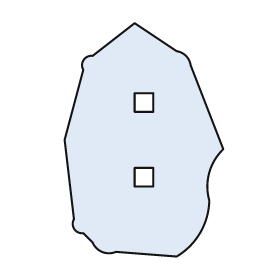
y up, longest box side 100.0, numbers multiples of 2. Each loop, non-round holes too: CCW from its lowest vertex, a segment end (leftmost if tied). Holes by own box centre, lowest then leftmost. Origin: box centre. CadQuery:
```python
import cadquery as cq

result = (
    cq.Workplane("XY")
    .moveTo(14.0, -50.0)
    .threePointArc((24.0, -40.0), (28.0, -26.0))
    .threePointArc((28.0, -14.0), (34.0, -4.0))
    .lineTo(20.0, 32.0)
    .threePointArc((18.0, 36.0), (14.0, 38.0))
    .lineTo(-4.0, 50.0)
    .lineTo(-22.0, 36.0)
    .threePointArc((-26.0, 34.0), (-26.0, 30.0))
    .lineTo(-34.0, 0.0)
    .lineTo(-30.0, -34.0)
    .threePointArc((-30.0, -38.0), (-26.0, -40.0))
    .lineTo(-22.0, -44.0)
    .threePointArc((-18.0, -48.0), (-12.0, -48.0))
    .close()
    .moveTo(-4.0, -20.0)
    .lineTo(4.0, -20.0)
    .lineTo(4.0, -12.0)
    .lineTo(-4.0, -12.0)
    .close()
    .moveTo(-4.0, 12.0)
    .lineTo(4.0, 12.0)
    .lineTo(4.0, 20.0)
    .lineTo(-4.0, 20.0)
    .close()
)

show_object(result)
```